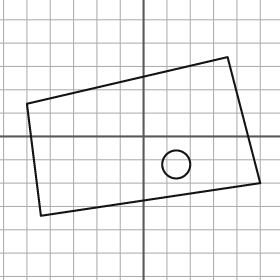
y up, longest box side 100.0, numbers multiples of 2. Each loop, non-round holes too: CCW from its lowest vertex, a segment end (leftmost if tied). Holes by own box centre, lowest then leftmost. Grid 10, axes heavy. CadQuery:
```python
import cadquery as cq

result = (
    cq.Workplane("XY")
    .moveTo(-44.0, -34.0)
    .lineTo(50.0, -20.0)
    .lineTo(36.0, 34.0)
    .lineTo(-50.0, 14.0)
    .close()
    .moveTo(14.0, -12.0)
    .circle(6.0)
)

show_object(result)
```